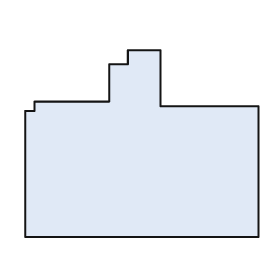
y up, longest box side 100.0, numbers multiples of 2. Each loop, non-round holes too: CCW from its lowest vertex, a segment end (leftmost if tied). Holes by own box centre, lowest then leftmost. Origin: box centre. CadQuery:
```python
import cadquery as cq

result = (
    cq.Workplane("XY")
    .moveTo(-50.0, -40.0)
    .lineTo(50.0, -40.0)
    .lineTo(50.0, 16.0)
    .lineTo(8.0, 16.0)
    .lineTo(8.0, 40.0)
    .lineTo(-6.0, 40.0)
    .lineTo(-6.0, 34.0)
    .lineTo(-14.0, 34.0)
    .lineTo(-14.0, 18.0)
    .lineTo(-46.0, 18.0)
    .lineTo(-46.0, 14.0)
    .lineTo(-50.0, 14.0)
    .close()
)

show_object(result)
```